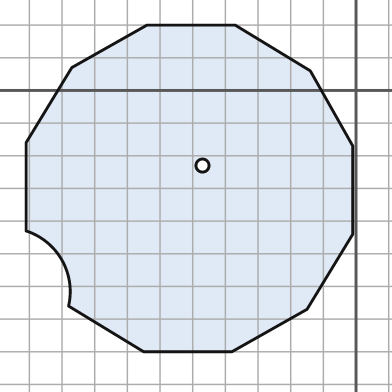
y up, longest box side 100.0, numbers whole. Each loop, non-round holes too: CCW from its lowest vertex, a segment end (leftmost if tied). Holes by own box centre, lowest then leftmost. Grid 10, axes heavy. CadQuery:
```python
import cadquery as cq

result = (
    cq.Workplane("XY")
    .moveTo(-65.0, -80.0)
    .lineTo(-38.0, -80.0)
    .lineTo(-15.0, -67.0)
    .lineTo(-1.0, -44.0)
    .lineTo(-1.0, -17.0)
    .lineTo(-14.0, 6.0)
    .lineTo(-37.0, 20.0)
    .lineTo(-64.0, 20.0)
    .lineTo(-87.0, 7.0)
    .lineTo(-101.0, -16.0)
    .lineTo(-101.0, -43.0)
    .threePointArc((-90.0, -52.0), (-88.0, -66.0))
    .close()
    .moveTo(-47.0, -23.0)
    .circle(2.0)
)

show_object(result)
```